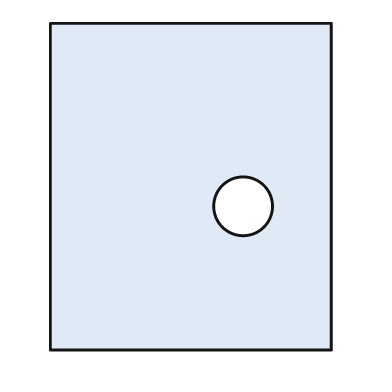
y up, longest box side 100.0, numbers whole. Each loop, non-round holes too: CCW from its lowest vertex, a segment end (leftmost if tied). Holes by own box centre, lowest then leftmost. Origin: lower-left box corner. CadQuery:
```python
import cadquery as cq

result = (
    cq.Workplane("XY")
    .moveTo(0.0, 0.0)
    .lineTo(86.0, 0.0)
    .lineTo(86.0, 100.0)
    .lineTo(0.0, 100.0)
    .close()
    .moveTo(59.0, 44.0)
    .circle(9.0)
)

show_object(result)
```